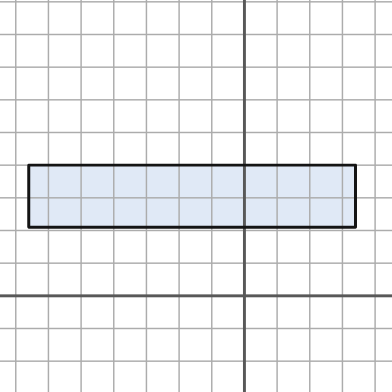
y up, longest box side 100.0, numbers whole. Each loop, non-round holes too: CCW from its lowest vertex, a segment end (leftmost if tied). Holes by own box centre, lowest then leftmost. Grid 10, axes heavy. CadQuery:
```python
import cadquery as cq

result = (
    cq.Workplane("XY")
    .moveTo(-66.0, 21.0)
    .lineTo(34.0, 21.0)
    .lineTo(34.0, 40.0)
    .lineTo(-66.0, 40.0)
    .close()
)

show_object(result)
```